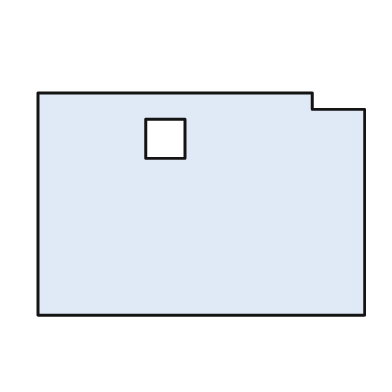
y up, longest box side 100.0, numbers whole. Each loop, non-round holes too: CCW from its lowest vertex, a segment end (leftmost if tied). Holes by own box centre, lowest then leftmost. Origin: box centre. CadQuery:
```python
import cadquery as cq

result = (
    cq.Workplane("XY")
    .moveTo(-50.0, -34.0)
    .lineTo(50.0, -34.0)
    .lineTo(50.0, 29.0)
    .lineTo(34.0, 29.0)
    .lineTo(34.0, 34.0)
    .lineTo(-50.0, 34.0)
    .close()
    .moveTo(-17.0, 14.0)
    .lineTo(-5.0, 14.0)
    .lineTo(-5.0, 26.0)
    .lineTo(-17.0, 26.0)
    .close()
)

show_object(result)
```